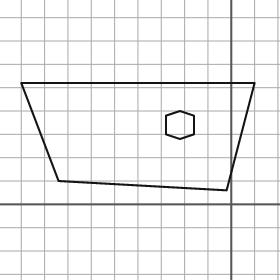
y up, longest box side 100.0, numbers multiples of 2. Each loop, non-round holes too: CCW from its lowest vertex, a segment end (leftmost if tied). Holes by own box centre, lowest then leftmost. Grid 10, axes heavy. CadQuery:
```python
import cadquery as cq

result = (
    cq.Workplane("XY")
    .moveTo(-2.0, 6.0)
    .lineTo(10.0, 52.0)
    .lineTo(-90.0, 52.0)
    .lineTo(-74.0, 10.0)
    .close()
    .moveTo(-22.0, 28.0)
    .lineTo(-16.0, 30.0)
    .lineTo(-16.0, 38.0)
    .lineTo(-22.0, 40.0)
    .lineTo(-28.0, 38.0)
    .lineTo(-28.0, 30.0)
    .close()
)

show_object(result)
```